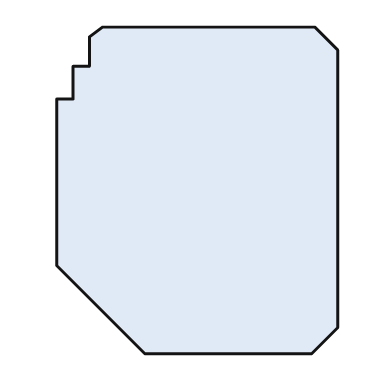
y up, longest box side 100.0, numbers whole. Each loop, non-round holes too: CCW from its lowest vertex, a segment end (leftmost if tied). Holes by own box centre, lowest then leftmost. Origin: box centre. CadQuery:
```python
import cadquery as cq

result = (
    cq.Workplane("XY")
    .moveTo(-16.0, -50.0)
    .lineTo(35.0, -50.0)
    .lineTo(43.0, -42.0)
    .lineTo(43.0, 43.0)
    .lineTo(36.0, 50.0)
    .lineTo(-29.0, 50.0)
    .lineTo(-33.0, 47.0)
    .lineTo(-33.0, 38.0)
    .lineTo(-38.0, 38.0)
    .lineTo(-38.0, 28.0)
    .lineTo(-43.0, 28.0)
    .lineTo(-43.0, -23.0)
    .close()
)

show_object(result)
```